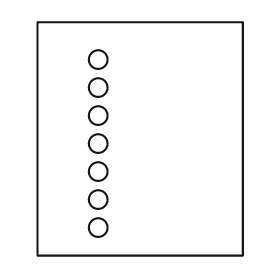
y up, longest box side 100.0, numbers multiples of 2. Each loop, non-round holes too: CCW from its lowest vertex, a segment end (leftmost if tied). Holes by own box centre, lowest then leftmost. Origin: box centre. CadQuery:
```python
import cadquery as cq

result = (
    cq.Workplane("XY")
    .moveTo(-44.0, -50.0)
    .lineTo(44.0, -50.0)
    .lineTo(44.0, 50.0)
    .lineTo(-44.0, 50.0)
    .close()
    .moveTo(-18.0, -38.0)
    .circle(4.0)
    .moveTo(-18.0, -26.0)
    .circle(4.0)
    .moveTo(-18.0, -14.0)
    .circle(4.0)
    .moveTo(-18.0, -2.0)
    .circle(4.0)
    .moveTo(-18.0, 10.0)
    .circle(4.0)
    .moveTo(-18.0, 22.0)
    .circle(4.0)
    .moveTo(-18.0, 34.0)
    .circle(4.0)
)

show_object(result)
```